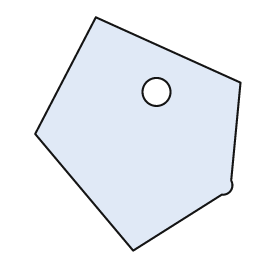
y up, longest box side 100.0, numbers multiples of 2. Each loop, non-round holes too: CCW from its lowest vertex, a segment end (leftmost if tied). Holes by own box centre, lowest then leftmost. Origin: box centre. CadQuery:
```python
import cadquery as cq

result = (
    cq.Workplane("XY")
    .moveTo(-2.0, -50.0)
    .lineTo(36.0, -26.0)
    .threePointArc((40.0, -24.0), (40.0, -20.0))
    .lineTo(44.0, 22.0)
    .lineTo(-18.0, 50.0)
    .lineTo(-44.0, 0.0)
    .close()
    .moveTo(8.0, 18.0)
    .circle(6.0)
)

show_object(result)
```